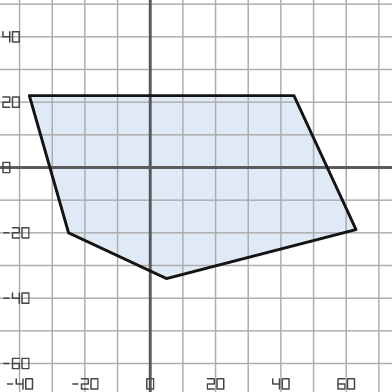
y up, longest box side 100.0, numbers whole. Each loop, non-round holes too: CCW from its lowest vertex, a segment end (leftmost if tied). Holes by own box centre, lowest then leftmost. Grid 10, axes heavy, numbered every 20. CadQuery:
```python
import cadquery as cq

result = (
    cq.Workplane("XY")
    .moveTo(5.0, -34.0)
    .lineTo(63.0, -19.0)
    .lineTo(44.0, 22.0)
    .lineTo(-37.0, 22.0)
    .lineTo(-25.0, -20.0)
    .close()
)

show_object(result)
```